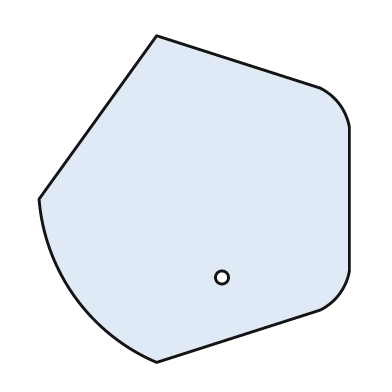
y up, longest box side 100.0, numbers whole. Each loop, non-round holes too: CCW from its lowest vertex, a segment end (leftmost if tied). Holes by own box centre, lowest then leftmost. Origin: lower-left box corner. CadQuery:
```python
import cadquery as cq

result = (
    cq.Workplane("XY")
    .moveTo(36.0, 0.0)
    .lineTo(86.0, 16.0)
    .threePointArc((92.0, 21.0), (95.0, 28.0))
    .lineTo(95.0, 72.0)
    .threePointArc((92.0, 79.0), (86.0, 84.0))
    .lineTo(36.0, 100.0)
    .lineTo(0.0, 50.0)
    .threePointArc((11.0, 20.0), (36.0, 0.0))
    .close()
    .moveTo(56.0, 26.0)
    .circle(2.0)
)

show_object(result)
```